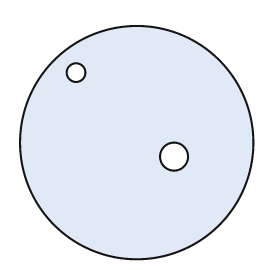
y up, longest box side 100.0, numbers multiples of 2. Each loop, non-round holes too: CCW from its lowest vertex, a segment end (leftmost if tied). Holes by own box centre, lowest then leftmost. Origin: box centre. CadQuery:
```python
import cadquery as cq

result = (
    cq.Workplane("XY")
    .moveTo(0.0, 0.0)
    .circle(50.0)
    .moveTo(16.0, -6.0)
    .circle(6.0)
    .moveTo(-26.0, 30.0)
    .circle(4.0)
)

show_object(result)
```